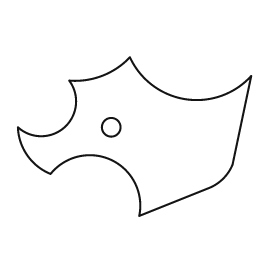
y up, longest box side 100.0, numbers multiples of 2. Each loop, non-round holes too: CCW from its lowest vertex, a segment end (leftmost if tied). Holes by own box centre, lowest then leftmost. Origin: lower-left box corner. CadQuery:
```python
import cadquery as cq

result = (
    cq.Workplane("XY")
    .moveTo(52.0, 0.0)
    .lineTo(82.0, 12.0)
    .threePointArc((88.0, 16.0), (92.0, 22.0))
    .lineTo(100.0, 60.0)
    .threePointArc((72.0, 50.0), (48.0, 68.0))
    .threePointArc((36.0, 60.0), (22.0, 58.0))
    .threePointArc((20.0, 38.0), (0.0, 38.0))
    .threePointArc((4.0, 26.0), (14.0, 18.0))
    .threePointArc((40.0, 24.0), (52.0, 0.0))
    .close()
    .moveTo(40.0, 38.0)
    .circle(4.0)
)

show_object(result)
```